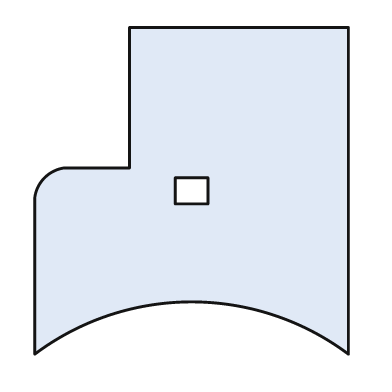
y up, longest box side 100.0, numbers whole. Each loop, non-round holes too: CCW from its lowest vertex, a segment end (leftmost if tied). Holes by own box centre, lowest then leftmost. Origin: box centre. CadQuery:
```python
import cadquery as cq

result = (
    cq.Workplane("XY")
    .moveTo(-48.0, -50.0)
    .threePointArc((0.0, -34.0), (48.0, -50.0))
    .lineTo(48.0, 50.0)
    .lineTo(-19.0, 50.0)
    .lineTo(-19.0, 7.0)
    .lineTo(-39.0, 7.0)
    .threePointArc((-45.0, 4.0), (-48.0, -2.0))
    .close()
    .moveTo(-5.0, -4.0)
    .lineTo(5.0, -4.0)
    .lineTo(5.0, 4.0)
    .lineTo(-5.0, 4.0)
    .close()
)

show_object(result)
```